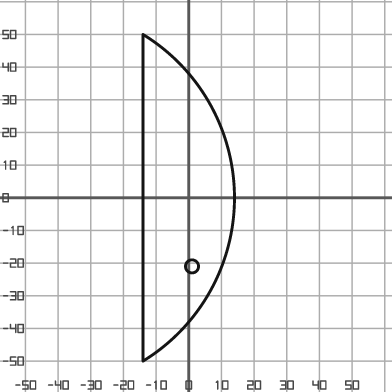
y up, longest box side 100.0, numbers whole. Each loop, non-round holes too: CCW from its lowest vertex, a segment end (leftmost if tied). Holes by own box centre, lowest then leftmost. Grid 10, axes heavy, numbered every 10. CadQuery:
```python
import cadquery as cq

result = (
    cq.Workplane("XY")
    .moveTo(-14.0, -50.0)
    .threePointArc((14.0, 0.0), (-14.0, 50.0))
    .close()
    .moveTo(1.0, -21.0)
    .circle(2.0)
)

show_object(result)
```